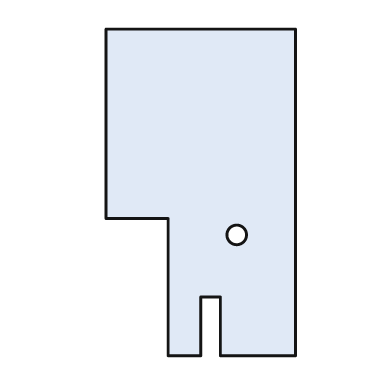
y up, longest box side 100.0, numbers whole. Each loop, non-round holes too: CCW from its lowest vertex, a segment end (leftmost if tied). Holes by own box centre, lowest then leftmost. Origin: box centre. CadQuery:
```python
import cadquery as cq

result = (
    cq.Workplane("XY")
    .moveTo(-10.0, -50.0)
    .lineTo(0.0, -50.0)
    .lineTo(0.0, -32.0)
    .lineTo(6.0, -32.0)
    .lineTo(6.0, -50.0)
    .lineTo(29.0, -50.0)
    .lineTo(29.0, 50.0)
    .lineTo(-29.0, 50.0)
    .lineTo(-29.0, -8.0)
    .lineTo(-10.0, -8.0)
    .close()
    .moveTo(11.0, -13.0)
    .circle(3.0)
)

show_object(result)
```